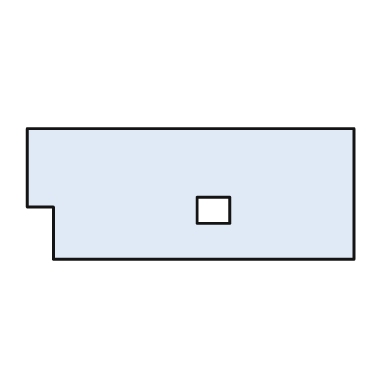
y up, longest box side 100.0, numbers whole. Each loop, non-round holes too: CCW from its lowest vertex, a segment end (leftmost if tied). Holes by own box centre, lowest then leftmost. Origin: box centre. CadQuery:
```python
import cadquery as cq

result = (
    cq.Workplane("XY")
    .moveTo(-42.0, -20.0)
    .lineTo(50.0, -20.0)
    .lineTo(50.0, 20.0)
    .lineTo(-50.0, 20.0)
    .lineTo(-50.0, -4.0)
    .lineTo(-42.0, -4.0)
    .close()
    .moveTo(2.0, -9.0)
    .lineTo(12.0, -9.0)
    .lineTo(12.0, -1.0)
    .lineTo(2.0, -1.0)
    .close()
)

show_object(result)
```